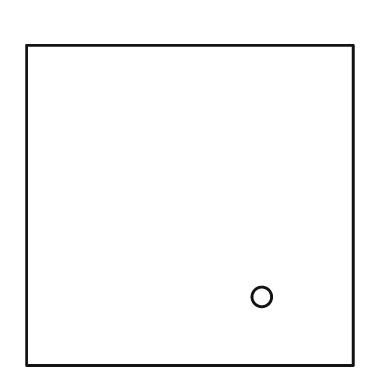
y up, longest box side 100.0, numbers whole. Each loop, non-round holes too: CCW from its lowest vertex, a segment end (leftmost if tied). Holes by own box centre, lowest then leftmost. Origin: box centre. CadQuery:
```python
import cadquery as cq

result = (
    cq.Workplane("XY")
    .moveTo(-50.0, -49.0)
    .lineTo(50.0, -49.0)
    .lineTo(50.0, 49.0)
    .lineTo(-50.0, 49.0)
    .close()
    .moveTo(22.0, -28.0)
    .circle(3.0)
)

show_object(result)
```